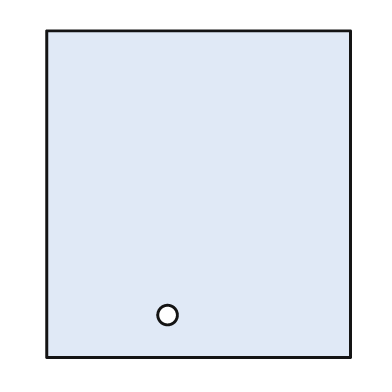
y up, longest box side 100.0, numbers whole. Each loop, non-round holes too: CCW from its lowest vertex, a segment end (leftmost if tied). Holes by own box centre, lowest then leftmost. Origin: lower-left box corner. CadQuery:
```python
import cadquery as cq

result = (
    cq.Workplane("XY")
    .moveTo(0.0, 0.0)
    .lineTo(93.0, 0.0)
    .lineTo(93.0, 100.0)
    .lineTo(0.0, 100.0)
    .close()
    .moveTo(37.0, 13.0)
    .circle(3.0)
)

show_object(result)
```